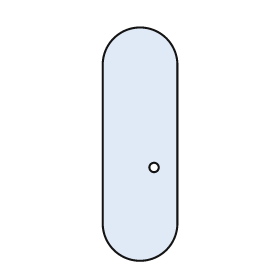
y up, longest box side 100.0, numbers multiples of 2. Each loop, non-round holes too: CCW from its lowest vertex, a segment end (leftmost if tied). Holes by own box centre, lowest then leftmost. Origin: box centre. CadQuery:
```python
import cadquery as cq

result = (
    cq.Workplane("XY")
    .moveTo(-16.0, -34.0)
    .threePointArc((0.0, -50.0), (16.0, -34.0))
    .lineTo(16.0, 34.0)
    .threePointArc((0.0, 50.0), (-16.0, 34.0))
    .close()
    .moveTo(6.0, -10.0)
    .circle(2.0)
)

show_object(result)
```